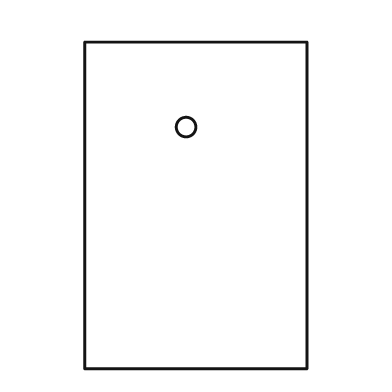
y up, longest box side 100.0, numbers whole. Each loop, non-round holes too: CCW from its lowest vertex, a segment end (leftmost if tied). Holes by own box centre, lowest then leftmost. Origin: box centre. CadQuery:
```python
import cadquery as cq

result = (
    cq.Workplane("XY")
    .moveTo(-34.0, -50.0)
    .lineTo(34.0, -50.0)
    .lineTo(34.0, 50.0)
    .lineTo(-34.0, 50.0)
    .close()
    .moveTo(-3.0, 24.0)
    .circle(3.0)
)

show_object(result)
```